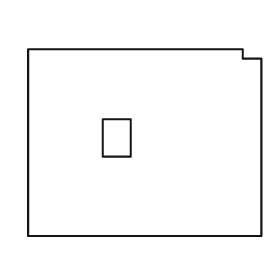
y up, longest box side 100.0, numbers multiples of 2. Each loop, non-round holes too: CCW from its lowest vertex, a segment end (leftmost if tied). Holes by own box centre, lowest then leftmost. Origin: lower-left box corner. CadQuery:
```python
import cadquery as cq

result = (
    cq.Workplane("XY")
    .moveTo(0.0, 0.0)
    .lineTo(100.0, 0.0)
    .lineTo(100.0, 76.0)
    .lineTo(92.0, 76.0)
    .lineTo(92.0, 80.0)
    .lineTo(0.0, 80.0)
    .close()
    .moveTo(32.0, 34.0)
    .lineTo(44.0, 34.0)
    .lineTo(44.0, 50.0)
    .lineTo(32.0, 50.0)
    .close()
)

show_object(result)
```